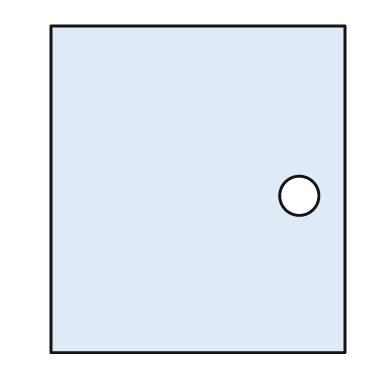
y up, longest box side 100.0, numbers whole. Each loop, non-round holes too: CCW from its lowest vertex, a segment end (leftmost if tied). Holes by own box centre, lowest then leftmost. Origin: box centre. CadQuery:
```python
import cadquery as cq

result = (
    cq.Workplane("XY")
    .moveTo(-45.0, -50.0)
    .lineTo(45.0, -50.0)
    .lineTo(45.0, 50.0)
    .lineTo(-45.0, 50.0)
    .close()
    .moveTo(31.0, -2.0)
    .circle(6.0)
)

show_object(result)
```